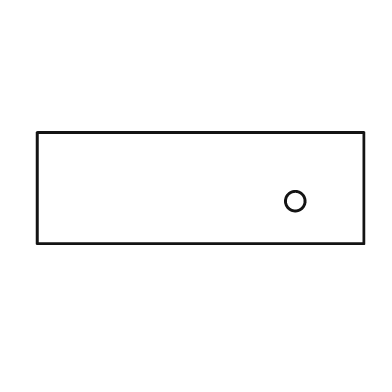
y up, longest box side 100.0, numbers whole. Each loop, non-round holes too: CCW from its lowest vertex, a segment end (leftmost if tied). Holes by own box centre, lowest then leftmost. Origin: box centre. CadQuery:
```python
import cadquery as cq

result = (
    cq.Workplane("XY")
    .moveTo(-50.0, -17.0)
    .lineTo(50.0, -17.0)
    .lineTo(50.0, 17.0)
    .lineTo(-50.0, 17.0)
    .close()
    .moveTo(29.0, -4.0)
    .circle(3.0)
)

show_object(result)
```